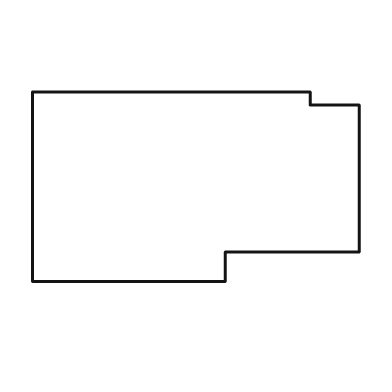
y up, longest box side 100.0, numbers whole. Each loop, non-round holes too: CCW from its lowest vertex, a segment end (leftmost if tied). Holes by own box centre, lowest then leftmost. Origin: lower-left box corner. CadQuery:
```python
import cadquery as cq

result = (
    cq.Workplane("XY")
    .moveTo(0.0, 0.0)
    .lineTo(59.0, 0.0)
    .lineTo(59.0, 9.0)
    .lineTo(100.0, 9.0)
    .lineTo(100.0, 54.0)
    .lineTo(85.0, 54.0)
    .lineTo(85.0, 58.0)
    .lineTo(0.0, 58.0)
    .close()
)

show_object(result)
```